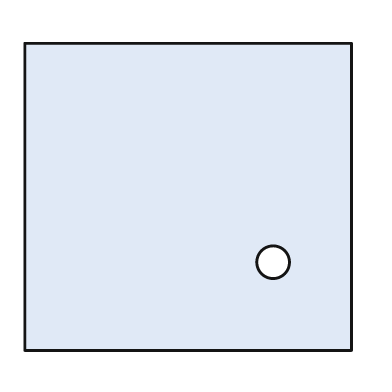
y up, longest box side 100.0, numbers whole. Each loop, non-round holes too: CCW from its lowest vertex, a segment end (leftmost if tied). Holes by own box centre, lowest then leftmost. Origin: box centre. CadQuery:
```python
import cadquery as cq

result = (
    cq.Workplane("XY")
    .moveTo(-50.0, -47.0)
    .lineTo(50.0, -47.0)
    .lineTo(50.0, 47.0)
    .lineTo(-50.0, 47.0)
    .close()
    .moveTo(26.0, -20.0)
    .circle(5.0)
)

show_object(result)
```